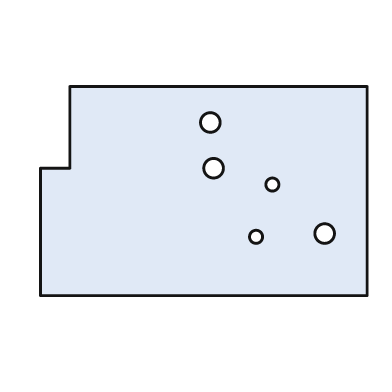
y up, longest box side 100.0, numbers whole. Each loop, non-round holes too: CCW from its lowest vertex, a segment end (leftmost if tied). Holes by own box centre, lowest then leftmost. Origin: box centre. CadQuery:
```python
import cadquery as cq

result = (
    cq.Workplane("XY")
    .moveTo(-50.0, -32.0)
    .lineTo(50.0, -32.0)
    .lineTo(50.0, 32.0)
    .lineTo(-41.0, 32.0)
    .lineTo(-41.0, 7.0)
    .lineTo(-50.0, 7.0)
    .close()
    .moveTo(16.0, -14.0)
    .circle(2.0)
    .moveTo(37.0, -13.0)
    .circle(3.0)
    .moveTo(21.0, 2.0)
    .circle(2.0)
    .moveTo(3.0, 7.0)
    .circle(3.0)
    .moveTo(2.0, 21.0)
    .circle(3.0)
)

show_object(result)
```